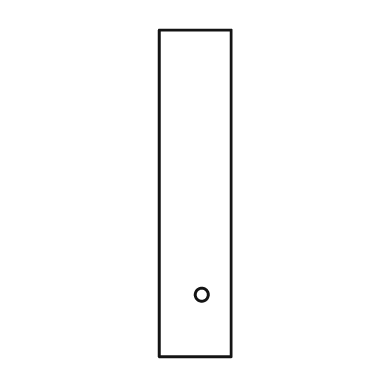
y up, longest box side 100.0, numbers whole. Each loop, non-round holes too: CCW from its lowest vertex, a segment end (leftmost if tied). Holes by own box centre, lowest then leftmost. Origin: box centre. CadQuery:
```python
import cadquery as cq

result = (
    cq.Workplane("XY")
    .moveTo(-11.0, -50.0)
    .lineTo(11.0, -50.0)
    .lineTo(11.0, 50.0)
    .lineTo(-11.0, 50.0)
    .close()
    .moveTo(2.0, -31.0)
    .circle(2.0)
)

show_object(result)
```